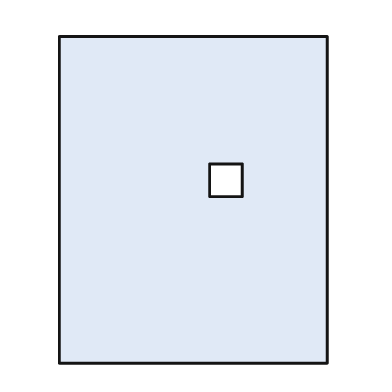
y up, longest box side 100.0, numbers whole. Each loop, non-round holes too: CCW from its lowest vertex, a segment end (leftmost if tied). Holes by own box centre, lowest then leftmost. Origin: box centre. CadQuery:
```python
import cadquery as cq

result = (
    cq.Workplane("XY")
    .moveTo(-41.0, -50.0)
    .lineTo(41.0, -50.0)
    .lineTo(41.0, 50.0)
    .lineTo(-41.0, 50.0)
    .close()
    .moveTo(5.0, 1.0)
    .lineTo(15.0, 1.0)
    .lineTo(15.0, 11.0)
    .lineTo(5.0, 11.0)
    .close()
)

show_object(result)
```